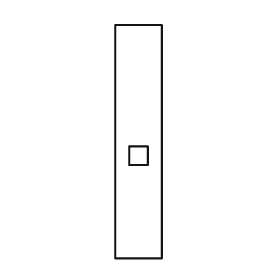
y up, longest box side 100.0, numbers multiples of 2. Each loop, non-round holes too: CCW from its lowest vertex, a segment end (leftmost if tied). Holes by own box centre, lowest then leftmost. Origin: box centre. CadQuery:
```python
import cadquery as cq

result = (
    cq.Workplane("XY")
    .moveTo(-10.0, -50.0)
    .lineTo(10.0, -50.0)
    .lineTo(10.0, 50.0)
    .lineTo(-10.0, 50.0)
    .close()
    .moveTo(-4.0, -10.0)
    .lineTo(4.0, -10.0)
    .lineTo(4.0, -2.0)
    .lineTo(-4.0, -2.0)
    .close()
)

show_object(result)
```